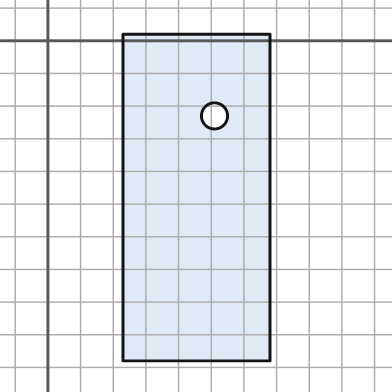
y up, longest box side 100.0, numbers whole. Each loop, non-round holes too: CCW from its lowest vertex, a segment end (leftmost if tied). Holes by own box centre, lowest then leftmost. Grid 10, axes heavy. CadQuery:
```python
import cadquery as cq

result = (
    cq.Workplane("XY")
    .moveTo(23.0, -98.0)
    .lineTo(68.0, -98.0)
    .lineTo(68.0, 2.0)
    .lineTo(23.0, 2.0)
    .close()
    .moveTo(51.0, -23.0)
    .circle(4.0)
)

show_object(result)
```